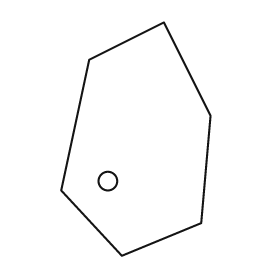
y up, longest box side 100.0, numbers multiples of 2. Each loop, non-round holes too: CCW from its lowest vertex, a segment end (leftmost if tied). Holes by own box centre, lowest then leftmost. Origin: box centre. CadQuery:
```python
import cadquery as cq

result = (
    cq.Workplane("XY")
    .moveTo(-6.0, -50.0)
    .lineTo(28.0, -36.0)
    .lineTo(32.0, 10.0)
    .lineTo(12.0, 50.0)
    .lineTo(-20.0, 34.0)
    .lineTo(-32.0, -22.0)
    .close()
    .moveTo(-12.0, -18.0)
    .circle(4.0)
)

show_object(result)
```